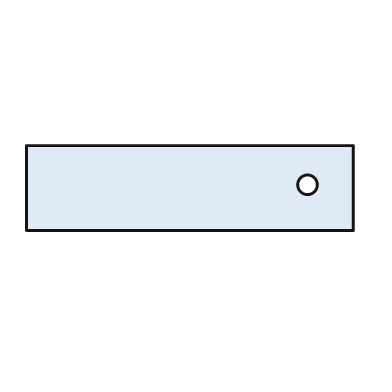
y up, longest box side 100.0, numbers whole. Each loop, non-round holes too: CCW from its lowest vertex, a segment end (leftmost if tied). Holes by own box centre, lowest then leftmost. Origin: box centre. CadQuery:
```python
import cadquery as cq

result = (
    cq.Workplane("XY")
    .moveTo(-50.0, -13.0)
    .lineTo(50.0, -13.0)
    .lineTo(50.0, 13.0)
    .lineTo(-50.0, 13.0)
    .close()
    .moveTo(36.0, 1.0)
    .circle(3.0)
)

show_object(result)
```